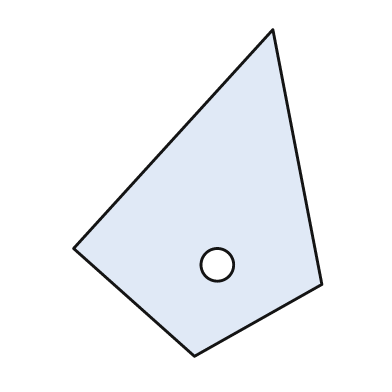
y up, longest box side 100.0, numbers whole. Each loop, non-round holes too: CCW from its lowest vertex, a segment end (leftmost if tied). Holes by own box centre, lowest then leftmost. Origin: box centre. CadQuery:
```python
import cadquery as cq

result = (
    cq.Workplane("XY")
    .moveTo(-1.0, -50.0)
    .lineTo(38.0, -28.0)
    .lineTo(23.0, 50.0)
    .lineTo(-38.0, -17.0)
    .close()
    .moveTo(6.0, -22.0)
    .circle(5.0)
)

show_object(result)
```